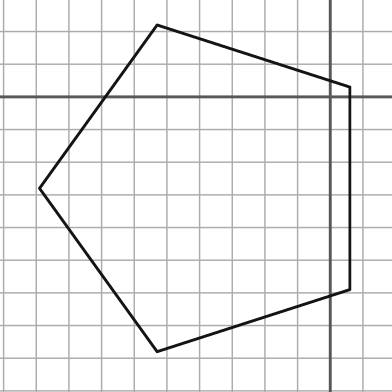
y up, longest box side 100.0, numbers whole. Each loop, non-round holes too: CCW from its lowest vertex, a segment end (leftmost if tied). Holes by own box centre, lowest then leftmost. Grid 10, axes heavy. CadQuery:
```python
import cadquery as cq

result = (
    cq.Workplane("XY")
    .moveTo(-53.0, -78.0)
    .lineTo(6.0, -59.0)
    .lineTo(6.0, 3.0)
    .lineTo(-53.0, 22.0)
    .lineTo(-89.0, -28.0)
    .close()
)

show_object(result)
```